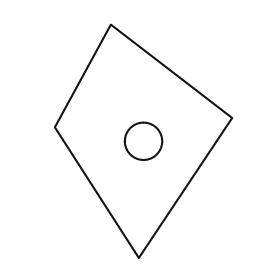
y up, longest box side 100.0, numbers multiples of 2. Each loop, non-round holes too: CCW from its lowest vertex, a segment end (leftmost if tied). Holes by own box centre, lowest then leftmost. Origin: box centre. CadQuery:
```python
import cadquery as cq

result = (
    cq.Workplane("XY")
    .moveTo(-2.0, -50.0)
    .lineTo(38.0, 10.0)
    .lineTo(-14.0, 50.0)
    .lineTo(-38.0, 6.0)
    .close()
    .moveTo(0.0, 0.0)
    .circle(8.0)
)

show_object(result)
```